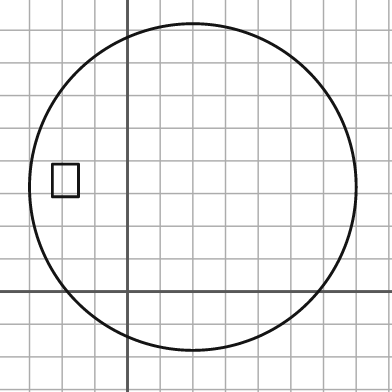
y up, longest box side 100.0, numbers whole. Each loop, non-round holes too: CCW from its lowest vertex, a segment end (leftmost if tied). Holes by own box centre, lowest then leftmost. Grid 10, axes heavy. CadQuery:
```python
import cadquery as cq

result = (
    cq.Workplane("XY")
    .moveTo(20.0, 32.0)
    .circle(50.0)
    .moveTo(-23.0, 29.0)
    .lineTo(-15.0, 29.0)
    .lineTo(-15.0, 39.0)
    .lineTo(-23.0, 39.0)
    .close()
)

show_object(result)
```